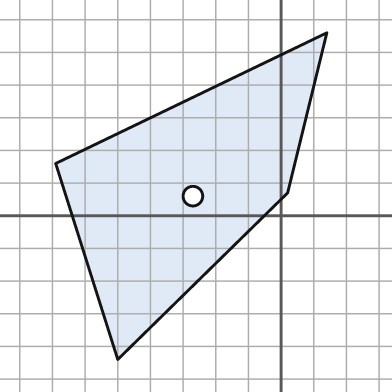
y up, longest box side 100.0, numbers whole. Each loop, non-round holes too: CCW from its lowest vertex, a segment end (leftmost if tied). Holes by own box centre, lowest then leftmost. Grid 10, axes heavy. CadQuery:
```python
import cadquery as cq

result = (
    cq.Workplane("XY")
    .moveTo(-50.0, -44.0)
    .lineTo(2.0, 7.0)
    .lineTo(14.0, 56.0)
    .lineTo(-69.0, 16.0)
    .close()
    .moveTo(-27.0, 6.0)
    .circle(3.0)
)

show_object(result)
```